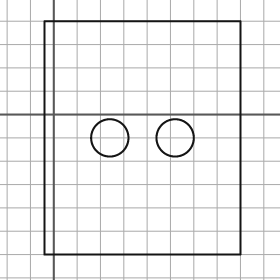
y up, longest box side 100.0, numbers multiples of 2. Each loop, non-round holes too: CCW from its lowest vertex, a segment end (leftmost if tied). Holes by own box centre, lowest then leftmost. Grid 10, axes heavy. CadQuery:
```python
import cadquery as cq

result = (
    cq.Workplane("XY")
    .moveTo(-4.0, -60.0)
    .lineTo(80.0, -60.0)
    .lineTo(80.0, 40.0)
    .lineTo(-4.0, 40.0)
    .close()
    .moveTo(24.0, -10.0)
    .circle(8.0)
    .moveTo(52.0, -10.0)
    .circle(8.0)
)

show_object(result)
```